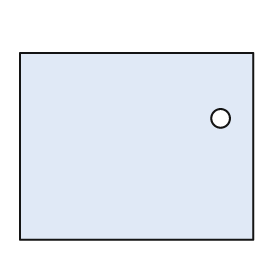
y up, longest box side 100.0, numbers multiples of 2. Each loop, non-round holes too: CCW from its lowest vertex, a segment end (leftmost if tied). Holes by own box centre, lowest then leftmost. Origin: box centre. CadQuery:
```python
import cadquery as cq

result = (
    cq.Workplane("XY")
    .moveTo(-50.0, -40.0)
    .lineTo(50.0, -40.0)
    .lineTo(50.0, 40.0)
    .lineTo(-50.0, 40.0)
    .close()
    .moveTo(36.0, 12.0)
    .circle(4.0)
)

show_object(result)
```